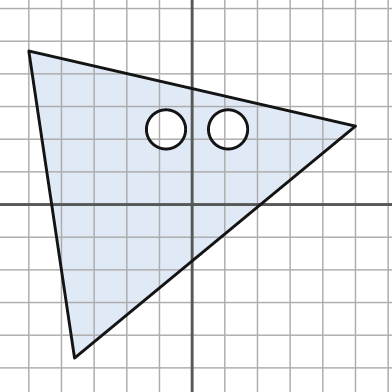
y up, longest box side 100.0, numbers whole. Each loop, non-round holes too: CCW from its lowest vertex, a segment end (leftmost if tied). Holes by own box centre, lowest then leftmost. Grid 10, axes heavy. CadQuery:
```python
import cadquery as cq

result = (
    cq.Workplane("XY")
    .moveTo(-36.0, -47.0)
    .lineTo(50.0, 24.0)
    .lineTo(-50.0, 47.0)
    .close()
    .moveTo(-8.0, 23.0)
    .circle(6.0)
    .moveTo(11.0, 23.0)
    .circle(6.0)
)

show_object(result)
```